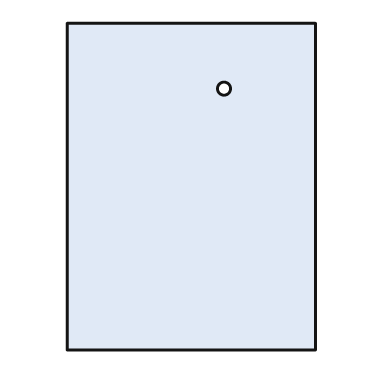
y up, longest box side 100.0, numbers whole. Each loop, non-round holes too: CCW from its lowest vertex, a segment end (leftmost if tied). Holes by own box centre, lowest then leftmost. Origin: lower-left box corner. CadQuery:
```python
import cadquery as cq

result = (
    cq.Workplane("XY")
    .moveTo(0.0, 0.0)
    .lineTo(76.0, 0.0)
    .lineTo(76.0, 100.0)
    .lineTo(0.0, 100.0)
    .close()
    .moveTo(48.0, 80.0)
    .circle(2.0)
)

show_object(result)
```